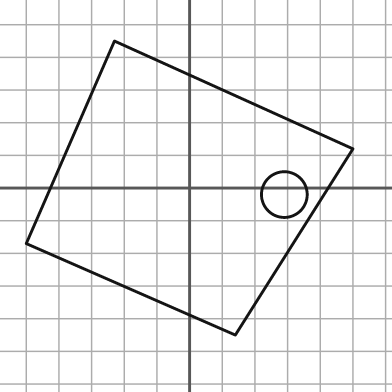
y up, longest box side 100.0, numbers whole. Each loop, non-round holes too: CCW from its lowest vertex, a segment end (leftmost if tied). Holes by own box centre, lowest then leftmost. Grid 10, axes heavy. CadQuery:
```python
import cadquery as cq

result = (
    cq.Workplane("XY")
    .moveTo(14.0, -45.0)
    .lineTo(50.0, 12.0)
    .lineTo(-23.0, 45.0)
    .lineTo(-50.0, -17.0)
    .close()
    .moveTo(29.0, -2.0)
    .circle(7.0)
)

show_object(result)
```